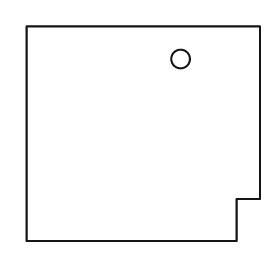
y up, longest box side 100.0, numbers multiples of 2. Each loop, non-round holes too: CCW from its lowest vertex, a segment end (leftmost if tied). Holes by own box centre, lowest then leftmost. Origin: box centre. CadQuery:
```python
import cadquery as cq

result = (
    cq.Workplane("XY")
    .moveTo(-50.0, -46.0)
    .lineTo(40.0, -46.0)
    .lineTo(40.0, -28.0)
    .lineTo(50.0, -28.0)
    .lineTo(50.0, 46.0)
    .lineTo(-50.0, 46.0)
    .close()
    .moveTo(16.0, 32.0)
    .circle(4.0)
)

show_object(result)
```